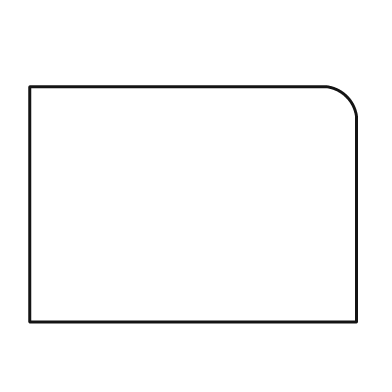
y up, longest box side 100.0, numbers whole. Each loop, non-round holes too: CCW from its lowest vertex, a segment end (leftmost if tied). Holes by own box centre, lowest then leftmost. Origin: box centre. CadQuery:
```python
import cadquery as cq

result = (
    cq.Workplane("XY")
    .moveTo(-50.0, -36.0)
    .lineTo(50.0, -36.0)
    .lineTo(50.0, 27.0)
    .threePointArc((47.0, 33.0), (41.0, 36.0))
    .lineTo(-50.0, 36.0)
    .close()
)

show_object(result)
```